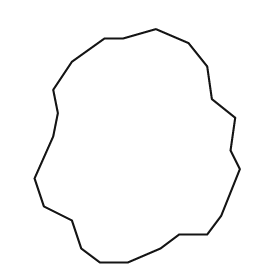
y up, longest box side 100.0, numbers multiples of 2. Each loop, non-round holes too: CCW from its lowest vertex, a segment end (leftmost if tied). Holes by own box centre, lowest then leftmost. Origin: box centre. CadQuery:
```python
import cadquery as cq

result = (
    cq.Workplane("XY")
    .moveTo(-16.0, -50.0)
    .lineTo(-4.0, -50.0)
    .lineTo(10.0, -44.0)
    .lineTo(18.0, -38.0)
    .lineTo(30.0, -38.0)
    .lineTo(36.0, -30.0)
    .lineTo(44.0, -10.0)
    .lineTo(40.0, -2.0)
    .lineTo(42.0, 12.0)
    .lineTo(32.0, 20.0)
    .lineTo(30.0, 34.0)
    .lineTo(22.0, 44.0)
    .lineTo(8.0, 50.0)
    .lineTo(-6.0, 46.0)
    .lineTo(-14.0, 46.0)
    .lineTo(-28.0, 36.0)
    .lineTo(-36.0, 24.0)
    .lineTo(-34.0, 14.0)
    .lineTo(-36.0, 4.0)
    .lineTo(-44.0, -14.0)
    .lineTo(-40.0, -26.0)
    .lineTo(-28.0, -32.0)
    .lineTo(-24.0, -44.0)
    .close()
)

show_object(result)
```